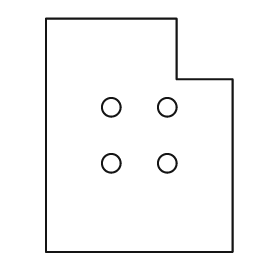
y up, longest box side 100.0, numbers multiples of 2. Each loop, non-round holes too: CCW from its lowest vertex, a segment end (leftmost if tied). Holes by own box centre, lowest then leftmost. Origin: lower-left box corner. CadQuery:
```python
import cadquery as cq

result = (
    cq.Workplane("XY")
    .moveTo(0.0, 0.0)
    .lineTo(80.0, 0.0)
    .lineTo(80.0, 74.0)
    .lineTo(56.0, 74.0)
    .lineTo(56.0, 100.0)
    .lineTo(0.0, 100.0)
    .close()
    .moveTo(28.0, 38.0)
    .circle(4.0)
    .moveTo(52.0, 38.0)
    .circle(4.0)
    .moveTo(28.0, 62.0)
    .circle(4.0)
    .moveTo(52.0, 62.0)
    .circle(4.0)
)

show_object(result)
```